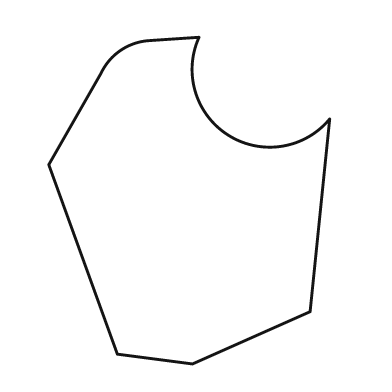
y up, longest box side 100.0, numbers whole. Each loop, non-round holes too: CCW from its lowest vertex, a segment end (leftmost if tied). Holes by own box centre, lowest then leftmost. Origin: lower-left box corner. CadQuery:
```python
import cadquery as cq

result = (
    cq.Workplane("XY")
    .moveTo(44.0, 0.0)
    .lineTo(80.0, 16.0)
    .lineTo(86.0, 75.0)
    .threePointArc((55.0, 70.0), (46.0, 100.0))
    .lineTo(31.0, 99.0)
    .threePointArc((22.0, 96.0), (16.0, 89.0))
    .lineTo(0.0, 61.0)
    .lineTo(21.0, 3.0)
    .close()
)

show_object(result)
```